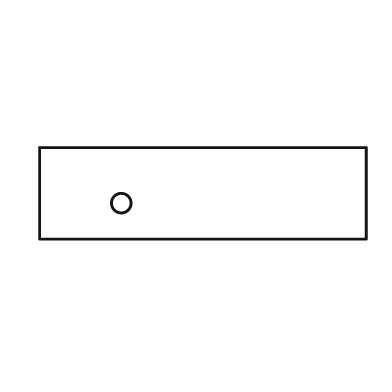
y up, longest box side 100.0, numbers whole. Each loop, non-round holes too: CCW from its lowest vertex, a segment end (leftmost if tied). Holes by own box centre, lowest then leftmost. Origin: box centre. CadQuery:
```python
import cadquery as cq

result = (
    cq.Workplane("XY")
    .moveTo(-50.0, -14.0)
    .lineTo(50.0, -14.0)
    .lineTo(50.0, 14.0)
    .lineTo(-50.0, 14.0)
    .close()
    .moveTo(-25.0, -3.0)
    .circle(3.0)
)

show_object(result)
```